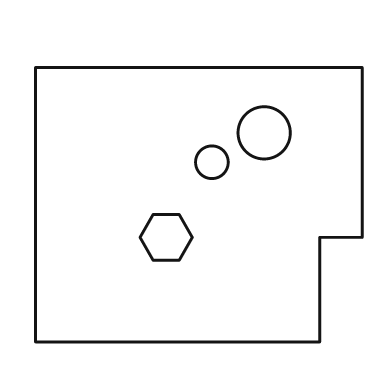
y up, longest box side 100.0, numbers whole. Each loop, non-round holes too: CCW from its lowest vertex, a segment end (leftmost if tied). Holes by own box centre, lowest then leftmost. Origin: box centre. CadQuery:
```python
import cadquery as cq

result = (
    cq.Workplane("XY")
    .moveTo(-50.0, -42.0)
    .lineTo(37.0, -42.0)
    .lineTo(37.0, -10.0)
    .lineTo(50.0, -10.0)
    .lineTo(50.0, 42.0)
    .lineTo(-50.0, 42.0)
    .close()
    .moveTo(-14.0, -17.0)
    .lineTo(-6.0, -17.0)
    .lineTo(-2.0, -10.0)
    .lineTo(-6.0, -3.0)
    .lineTo(-14.0, -3.0)
    .lineTo(-18.0, -10.0)
    .close()
    .moveTo(4.0, 13.0)
    .circle(5.0)
    .moveTo(20.0, 22.0)
    .circle(8.0)
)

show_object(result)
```